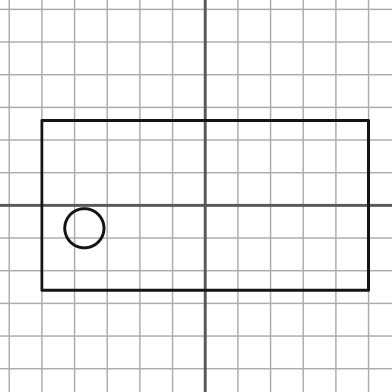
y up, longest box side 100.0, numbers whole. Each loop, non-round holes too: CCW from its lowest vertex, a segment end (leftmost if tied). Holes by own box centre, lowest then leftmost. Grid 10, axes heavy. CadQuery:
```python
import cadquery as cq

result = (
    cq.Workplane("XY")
    .moveTo(-50.0, -26.0)
    .lineTo(50.0, -26.0)
    .lineTo(50.0, 26.0)
    .lineTo(-50.0, 26.0)
    .close()
    .moveTo(-37.0, -7.0)
    .circle(6.0)
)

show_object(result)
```